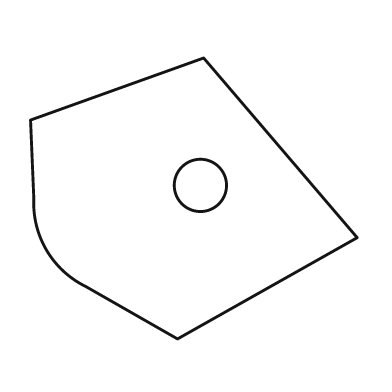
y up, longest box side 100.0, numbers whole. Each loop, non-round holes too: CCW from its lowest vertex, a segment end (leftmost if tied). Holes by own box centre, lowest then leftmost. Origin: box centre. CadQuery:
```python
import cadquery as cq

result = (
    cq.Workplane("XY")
    .moveTo(-5.0, -43.0)
    .lineTo(50.0, -12.0)
    .lineTo(3.0, 43.0)
    .lineTo(-50.0, 24.0)
    .lineTo(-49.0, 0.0)
    .threePointArc((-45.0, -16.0), (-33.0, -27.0))
    .close()
    .moveTo(2.0, 4.0)
    .circle(8.0)
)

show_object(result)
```